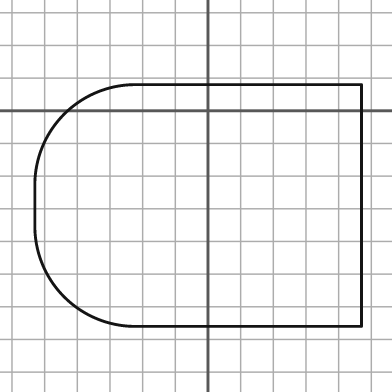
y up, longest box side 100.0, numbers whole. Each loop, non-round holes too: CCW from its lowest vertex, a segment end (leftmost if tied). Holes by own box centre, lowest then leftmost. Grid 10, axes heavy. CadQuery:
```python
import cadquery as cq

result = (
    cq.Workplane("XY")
    .moveTo(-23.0, -66.0)
    .lineTo(47.0, -66.0)
    .lineTo(47.0, 8.0)
    .lineTo(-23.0, 8.0)
    .threePointArc((-44.0, -1.0), (-53.0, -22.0))
    .lineTo(-53.0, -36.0)
    .threePointArc((-44.0, -57.0), (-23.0, -66.0))
    .close()
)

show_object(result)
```